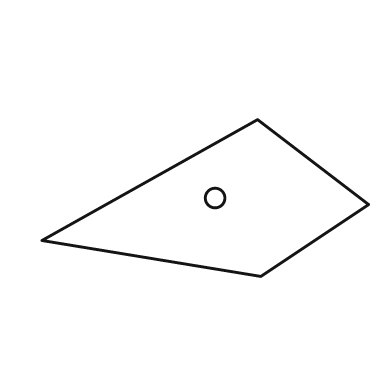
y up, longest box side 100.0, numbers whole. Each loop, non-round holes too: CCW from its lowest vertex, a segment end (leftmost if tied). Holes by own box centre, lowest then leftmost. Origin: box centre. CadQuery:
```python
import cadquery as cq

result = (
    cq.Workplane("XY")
    .moveTo(17.0, -24.0)
    .lineTo(50.0, -2.0)
    .lineTo(16.0, 24.0)
    .lineTo(-50.0, -13.0)
    .close()
    .moveTo(3.0, 0.0)
    .circle(3.0)
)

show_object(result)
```